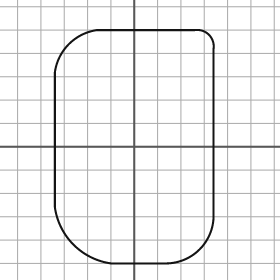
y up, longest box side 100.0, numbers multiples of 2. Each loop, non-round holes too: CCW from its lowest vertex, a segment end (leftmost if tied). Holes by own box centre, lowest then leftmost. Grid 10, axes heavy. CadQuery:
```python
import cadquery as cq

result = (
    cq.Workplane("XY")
    .moveTo(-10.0, -50.0)
    .lineTo(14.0, -50.0)
    .threePointArc((28.0, -44.0), (34.0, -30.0))
    .lineTo(34.0, 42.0)
    .threePointArc((32.0, 48.0), (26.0, 50.0))
    .lineTo(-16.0, 50.0)
    .threePointArc((-28.0, 44.0), (-34.0, 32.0))
    .lineTo(-34.0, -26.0)
    .threePointArc((-26.0, -42.0), (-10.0, -50.0))
    .close()
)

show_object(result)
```